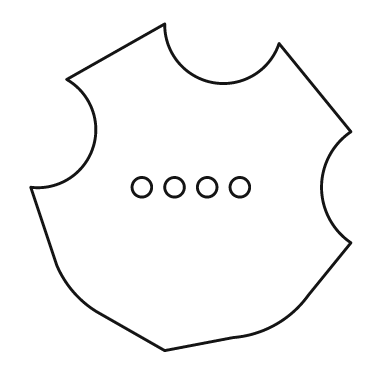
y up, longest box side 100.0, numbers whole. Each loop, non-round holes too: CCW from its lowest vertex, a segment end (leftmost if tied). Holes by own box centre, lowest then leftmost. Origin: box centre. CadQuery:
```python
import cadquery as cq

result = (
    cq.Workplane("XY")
    .moveTo(-8.0, -50.0)
    .lineTo(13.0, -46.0)
    .threePointArc((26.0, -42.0), (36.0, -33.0))
    .lineTo(49.0, -17.0)
    .threePointArc((40.0, 0.0), (49.0, 17.0))
    .lineTo(27.0, 44.0)
    .threePointArc((7.0, 32.0), (-8.0, 50.0))
    .lineTo(-38.0, 33.0)
    .threePointArc((-30.0, 12.0), (-49.0, 0.0))
    .lineTo(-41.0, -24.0)
    .threePointArc((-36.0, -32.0), (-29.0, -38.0))
    .close()
    .moveTo(-15.0, 0.0)
    .circle(3.0)
    .moveTo(-5.0, 0.0)
    .circle(3.0)
    .moveTo(5.0, 0.0)
    .circle(3.0)
    .moveTo(15.0, 0.0)
    .circle(3.0)
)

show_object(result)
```